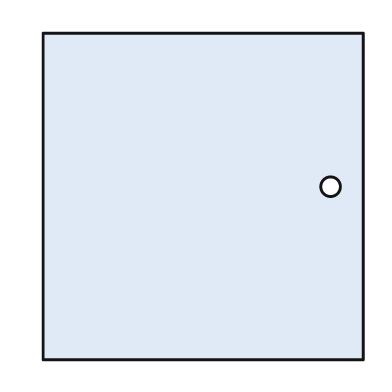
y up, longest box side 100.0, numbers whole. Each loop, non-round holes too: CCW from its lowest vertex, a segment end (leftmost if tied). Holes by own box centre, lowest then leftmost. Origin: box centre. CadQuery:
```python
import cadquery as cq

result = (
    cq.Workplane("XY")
    .moveTo(-49.0, -50.0)
    .lineTo(49.0, -50.0)
    .lineTo(49.0, 50.0)
    .lineTo(-49.0, 50.0)
    .close()
    .moveTo(39.0, 3.0)
    .circle(3.0)
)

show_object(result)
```